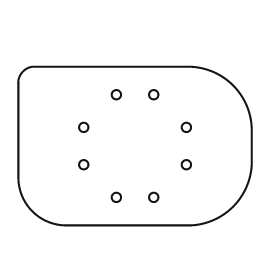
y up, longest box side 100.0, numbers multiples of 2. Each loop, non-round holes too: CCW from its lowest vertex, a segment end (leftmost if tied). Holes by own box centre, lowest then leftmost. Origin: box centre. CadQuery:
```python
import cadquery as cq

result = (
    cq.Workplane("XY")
    .moveTo(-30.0, -34.0)
    .lineTo(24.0, -34.0)
    .threePointArc((42.0, -26.0), (50.0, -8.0))
    .lineTo(50.0, 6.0)
    .threePointArc((42.0, 26.0), (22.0, 34.0))
    .lineTo(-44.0, 34.0)
    .threePointArc((-48.0, 32.0), (-50.0, 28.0))
    .lineTo(-50.0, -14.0)
    .threePointArc((-44.0, -28.0), (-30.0, -34.0))
    .close()
    .moveTo(-8.0, -22.0)
    .circle(2.0)
    .moveTo(8.0, -22.0)
    .circle(2.0)
    .moveTo(-22.0, -8.0)
    .circle(2.0)
    .moveTo(22.0, -8.0)
    .circle(2.0)
    .moveTo(-22.0, 8.0)
    .circle(2.0)
    .moveTo(22.0, 8.0)
    .circle(2.0)
    .moveTo(-8.0, 22.0)
    .circle(2.0)
    .moveTo(8.0, 22.0)
    .circle(2.0)
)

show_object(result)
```